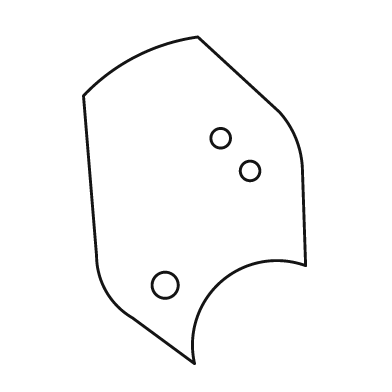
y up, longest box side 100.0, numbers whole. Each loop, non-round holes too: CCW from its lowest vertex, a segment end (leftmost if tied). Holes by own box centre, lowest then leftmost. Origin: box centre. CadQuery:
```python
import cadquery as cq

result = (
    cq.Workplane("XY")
    .moveTo(0.0, -50.0)
    .threePointArc((8.0, -25.0), (34.0, -20.0))
    .lineTo(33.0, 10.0)
    .threePointArc((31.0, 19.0), (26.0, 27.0))
    .lineTo(1.0, 50.0)
    .threePointArc((-18.0, 44.0), (-34.0, 32.0))
    .lineTo(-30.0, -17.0)
    .threePointArc((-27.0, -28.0), (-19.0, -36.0))
    .close()
    .moveTo(-9.0, -26.0)
    .circle(4.0)
    .moveTo(17.0, 9.0)
    .circle(3.0)
    .moveTo(8.0, 19.0)
    .circle(3.0)
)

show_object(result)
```